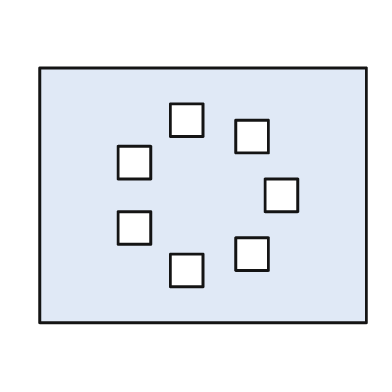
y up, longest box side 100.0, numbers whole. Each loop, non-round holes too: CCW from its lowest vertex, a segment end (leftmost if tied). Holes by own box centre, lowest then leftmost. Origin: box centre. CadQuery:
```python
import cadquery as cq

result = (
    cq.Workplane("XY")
    .moveTo(-50.0, -39.0)
    .lineTo(50.0, -39.0)
    .lineTo(50.0, 39.0)
    .lineTo(-50.0, 39.0)
    .close()
    .moveTo(-10.0, -28.0)
    .lineTo(0.0, -28.0)
    .lineTo(0.0, -18.0)
    .lineTo(-10.0, -18.0)
    .close()
    .moveTo(10.0, -23.0)
    .lineTo(20.0, -23.0)
    .lineTo(20.0, -13.0)
    .lineTo(10.0, -13.0)
    .close()
    .moveTo(-26.0, -15.0)
    .lineTo(-16.0, -15.0)
    .lineTo(-16.0, -5.0)
    .lineTo(-26.0, -5.0)
    .close()
    .moveTo(19.0, -5.0)
    .lineTo(29.0, -5.0)
    .lineTo(29.0, 5.0)
    .lineTo(19.0, 5.0)
    .close()
    .moveTo(-26.0, 5.0)
    .lineTo(-16.0, 5.0)
    .lineTo(-16.0, 15.0)
    .lineTo(-26.0, 15.0)
    .close()
    .moveTo(10.0, 13.0)
    .lineTo(20.0, 13.0)
    .lineTo(20.0, 23.0)
    .lineTo(10.0, 23.0)
    .close()
    .moveTo(-10.0, 18.0)
    .lineTo(0.0, 18.0)
    .lineTo(0.0, 28.0)
    .lineTo(-10.0, 28.0)
    .close()
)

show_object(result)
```